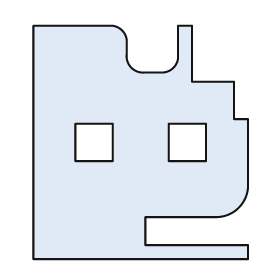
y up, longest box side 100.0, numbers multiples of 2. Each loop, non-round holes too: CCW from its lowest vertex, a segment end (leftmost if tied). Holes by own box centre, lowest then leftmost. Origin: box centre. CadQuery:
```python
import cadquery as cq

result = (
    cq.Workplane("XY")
    .moveTo(-46.0, -50.0)
    .lineTo(46.0, -50.0)
    .lineTo(46.0, -44.0)
    .lineTo(2.0, -44.0)
    .lineTo(2.0, -32.0)
    .lineTo(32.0, -32.0)
    .threePointArc((42.0, -28.0), (46.0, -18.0))
    .lineTo(46.0, 10.0)
    .lineTo(40.0, 10.0)
    .lineTo(40.0, 26.0)
    .lineTo(22.0, 26.0)
    .lineTo(22.0, 50.0)
    .lineTo(16.0, 50.0)
    .lineTo(16.0, 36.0)
    .threePointArc((14.0, 32.0), (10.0, 30.0))
    .lineTo(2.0, 30.0)
    .threePointArc((-4.0, 32.0), (-6.0, 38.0))
    .lineTo(-6.0, 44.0)
    .threePointArc((-8.0, 48.0), (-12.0, 50.0))
    .lineTo(-46.0, 50.0)
    .close()
    .moveTo(-28.0, -8.0)
    .lineTo(-12.0, -8.0)
    .lineTo(-12.0, 8.0)
    .lineTo(-28.0, 8.0)
    .close()
    .moveTo(12.0, -8.0)
    .lineTo(28.0, -8.0)
    .lineTo(28.0, 8.0)
    .lineTo(12.0, 8.0)
    .close()
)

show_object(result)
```